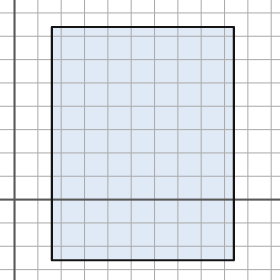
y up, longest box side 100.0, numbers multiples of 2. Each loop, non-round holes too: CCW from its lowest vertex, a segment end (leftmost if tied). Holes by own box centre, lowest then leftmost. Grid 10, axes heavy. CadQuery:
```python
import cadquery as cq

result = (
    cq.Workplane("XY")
    .moveTo(16.0, -26.0)
    .lineTo(94.0, -26.0)
    .lineTo(94.0, 74.0)
    .lineTo(16.0, 74.0)
    .close()
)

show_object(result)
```